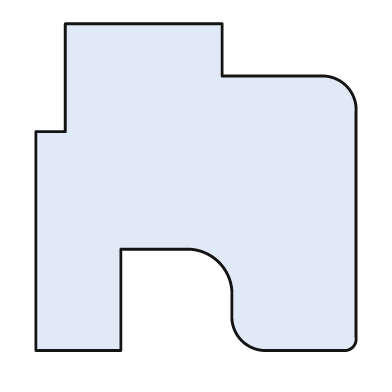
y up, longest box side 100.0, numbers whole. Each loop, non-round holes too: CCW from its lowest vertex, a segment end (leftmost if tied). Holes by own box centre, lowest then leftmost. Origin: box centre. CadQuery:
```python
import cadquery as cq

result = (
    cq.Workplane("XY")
    .moveTo(-49.0, -50.0)
    .lineTo(-23.0, -50.0)
    .lineTo(-23.0, -19.0)
    .lineTo(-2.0, -19.0)
    .threePointArc((7.0, -23.0), (11.0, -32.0))
    .lineTo(11.0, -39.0)
    .threePointArc((14.0, -47.0), (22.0, -50.0))
    .lineTo(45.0, -50.0)
    .threePointArc((48.0, -49.0), (49.0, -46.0))
    .lineTo(49.0, 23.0)
    .threePointArc((46.0, 31.0), (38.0, 34.0))
    .lineTo(8.0, 34.0)
    .lineTo(8.0, 50.0)
    .lineTo(-40.0, 50.0)
    .lineTo(-40.0, 17.0)
    .lineTo(-49.0, 17.0)
    .close()
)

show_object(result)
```